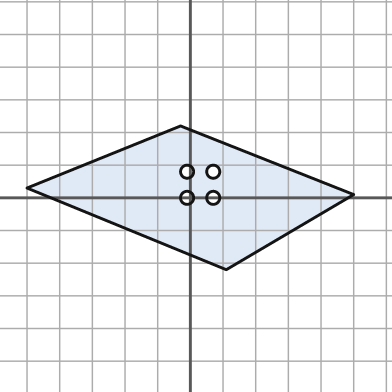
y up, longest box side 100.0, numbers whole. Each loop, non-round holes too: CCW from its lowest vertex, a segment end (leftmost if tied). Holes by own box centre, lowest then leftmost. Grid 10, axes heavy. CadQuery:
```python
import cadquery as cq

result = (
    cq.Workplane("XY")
    .moveTo(11.0, -22.0)
    .lineTo(50.0, 1.0)
    .lineTo(-3.0, 22.0)
    .lineTo(-50.0, 3.0)
    .close()
    .moveTo(-1.0, 0.0)
    .circle(2.0)
    .moveTo(7.0, 0.0)
    .circle(2.0)
    .moveTo(-1.0, 8.0)
    .circle(2.0)
    .moveTo(7.0, 8.0)
    .circle(2.0)
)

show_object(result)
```